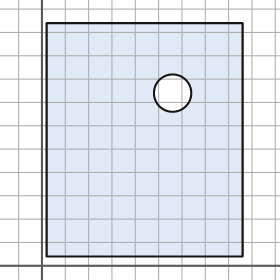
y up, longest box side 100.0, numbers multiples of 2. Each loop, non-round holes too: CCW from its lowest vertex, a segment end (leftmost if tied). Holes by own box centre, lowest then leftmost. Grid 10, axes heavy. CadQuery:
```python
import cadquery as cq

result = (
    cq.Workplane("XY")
    .moveTo(2.0, 4.0)
    .lineTo(86.0, 4.0)
    .lineTo(86.0, 104.0)
    .lineTo(2.0, 104.0)
    .close()
    .moveTo(56.0, 74.0)
    .circle(8.0)
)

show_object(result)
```